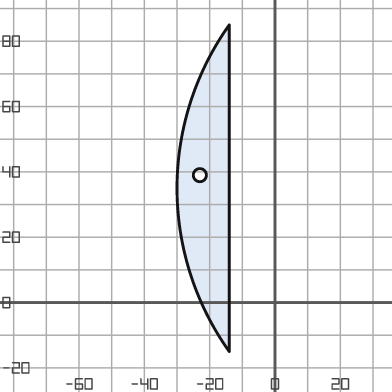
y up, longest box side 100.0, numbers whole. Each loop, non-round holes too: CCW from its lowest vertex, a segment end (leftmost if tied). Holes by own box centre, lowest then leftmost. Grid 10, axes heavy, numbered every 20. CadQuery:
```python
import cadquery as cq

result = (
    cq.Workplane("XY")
    .moveTo(-14.0, -15.0)
    .lineTo(-14.0, 85.0)
    .threePointArc((-30.0, 35.0), (-14.0, -15.0))
    .close()
    .moveTo(-23.0, 39.0)
    .circle(2.0)
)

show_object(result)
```